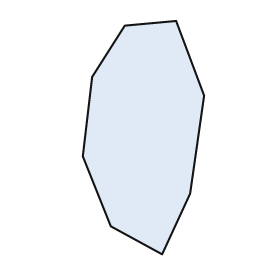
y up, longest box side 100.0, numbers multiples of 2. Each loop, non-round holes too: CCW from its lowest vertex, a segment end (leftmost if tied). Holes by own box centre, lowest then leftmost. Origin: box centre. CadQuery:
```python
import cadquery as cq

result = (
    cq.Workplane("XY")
    .moveTo(8.0, -50.0)
    .lineTo(20.0, -24.0)
    .lineTo(26.0, 18.0)
    .lineTo(14.0, 50.0)
    .lineTo(-8.0, 48.0)
    .lineTo(-22.0, 26.0)
    .lineTo(-26.0, -8.0)
    .lineTo(-14.0, -38.0)
    .close()
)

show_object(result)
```